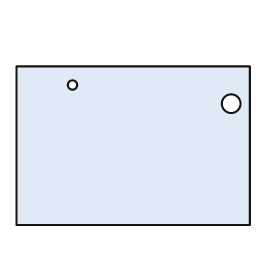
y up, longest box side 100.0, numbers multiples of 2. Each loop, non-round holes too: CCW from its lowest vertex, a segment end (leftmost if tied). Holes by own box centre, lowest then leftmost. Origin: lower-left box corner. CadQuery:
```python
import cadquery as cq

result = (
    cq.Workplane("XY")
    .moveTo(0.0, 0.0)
    .lineTo(100.0, 0.0)
    .lineTo(100.0, 68.0)
    .lineTo(0.0, 68.0)
    .close()
    .moveTo(92.0, 52.0)
    .circle(4.0)
    .moveTo(24.0, 60.0)
    .circle(2.0)
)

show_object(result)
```